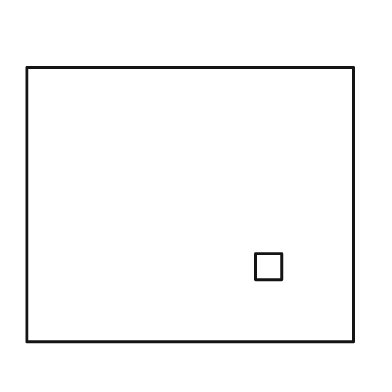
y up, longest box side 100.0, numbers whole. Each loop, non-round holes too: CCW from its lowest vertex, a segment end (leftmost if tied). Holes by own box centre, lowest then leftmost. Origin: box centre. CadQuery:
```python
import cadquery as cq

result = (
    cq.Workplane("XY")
    .moveTo(-50.0, -42.0)
    .lineTo(50.0, -42.0)
    .lineTo(50.0, 42.0)
    .lineTo(-50.0, 42.0)
    .close()
    .moveTo(20.0, -23.0)
    .lineTo(28.0, -23.0)
    .lineTo(28.0, -15.0)
    .lineTo(20.0, -15.0)
    .close()
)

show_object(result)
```